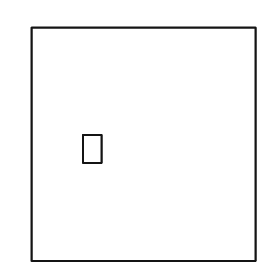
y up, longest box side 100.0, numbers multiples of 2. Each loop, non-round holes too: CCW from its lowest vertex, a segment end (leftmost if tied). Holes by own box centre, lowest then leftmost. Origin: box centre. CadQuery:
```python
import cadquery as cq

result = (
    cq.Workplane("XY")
    .moveTo(-48.0, -50.0)
    .lineTo(48.0, -50.0)
    .lineTo(48.0, 50.0)
    .lineTo(-48.0, 50.0)
    .close()
    .moveTo(-26.0, -8.0)
    .lineTo(-18.0, -8.0)
    .lineTo(-18.0, 4.0)
    .lineTo(-26.0, 4.0)
    .close()
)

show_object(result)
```